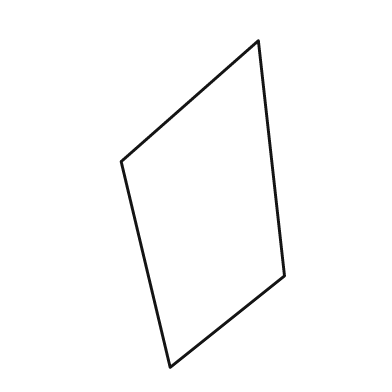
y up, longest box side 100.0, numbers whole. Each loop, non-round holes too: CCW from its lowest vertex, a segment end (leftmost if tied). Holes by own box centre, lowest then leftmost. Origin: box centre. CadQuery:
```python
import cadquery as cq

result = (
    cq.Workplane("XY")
    .moveTo(-10.0, -50.0)
    .lineTo(25.0, -22.0)
    .lineTo(17.0, 50.0)
    .lineTo(-25.0, 13.0)
    .close()
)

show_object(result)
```